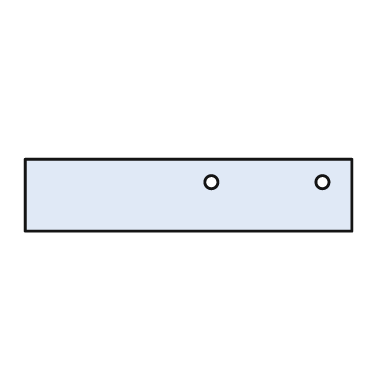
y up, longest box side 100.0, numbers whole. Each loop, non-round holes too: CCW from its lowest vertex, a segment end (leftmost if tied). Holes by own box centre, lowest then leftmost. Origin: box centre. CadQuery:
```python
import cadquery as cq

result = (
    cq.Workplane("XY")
    .moveTo(-50.0, -11.0)
    .lineTo(50.0, -11.0)
    .lineTo(50.0, 11.0)
    .lineTo(-50.0, 11.0)
    .close()
    .moveTo(7.0, 4.0)
    .circle(2.0)
    .moveTo(41.0, 4.0)
    .circle(2.0)
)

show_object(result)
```